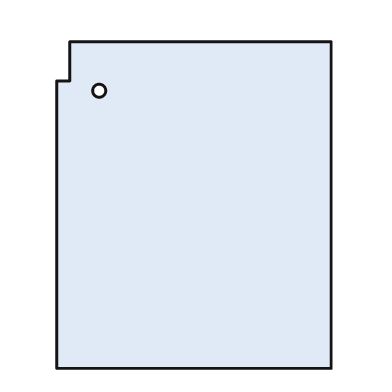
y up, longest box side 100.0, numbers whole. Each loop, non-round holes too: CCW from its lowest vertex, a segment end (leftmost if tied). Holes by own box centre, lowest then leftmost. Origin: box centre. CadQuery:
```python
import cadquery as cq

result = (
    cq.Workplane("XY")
    .moveTo(-42.0, -50.0)
    .lineTo(42.0, -50.0)
    .lineTo(42.0, 50.0)
    .lineTo(-38.0, 50.0)
    .lineTo(-38.0, 38.0)
    .lineTo(-42.0, 38.0)
    .close()
    .moveTo(-29.0, 35.0)
    .circle(2.0)
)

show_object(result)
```